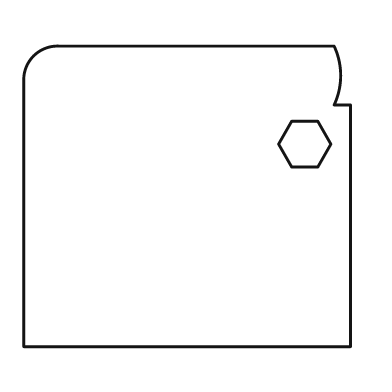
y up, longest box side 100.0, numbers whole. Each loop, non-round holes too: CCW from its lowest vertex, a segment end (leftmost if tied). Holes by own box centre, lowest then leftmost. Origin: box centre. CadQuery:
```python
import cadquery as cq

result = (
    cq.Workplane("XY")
    .moveTo(-50.0, -46.0)
    .lineTo(50.0, -46.0)
    .lineTo(50.0, 28.0)
    .lineTo(45.0, 28.0)
    .threePointArc((47.0, 37.0), (45.0, 46.0))
    .lineTo(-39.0, 46.0)
    .threePointArc((-47.0, 43.0), (-50.0, 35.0))
    .close()
    .moveTo(32.0, 9.0)
    .lineTo(40.0, 9.0)
    .lineTo(44.0, 16.0)
    .lineTo(40.0, 23.0)
    .lineTo(32.0, 23.0)
    .lineTo(28.0, 16.0)
    .close()
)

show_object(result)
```